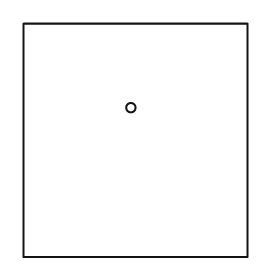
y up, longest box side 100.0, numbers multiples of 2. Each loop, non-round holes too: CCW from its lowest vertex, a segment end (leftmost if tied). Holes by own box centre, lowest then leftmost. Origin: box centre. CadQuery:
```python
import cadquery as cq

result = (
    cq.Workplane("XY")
    .moveTo(-48.0, -50.0)
    .lineTo(48.0, -50.0)
    .lineTo(48.0, 50.0)
    .lineTo(-48.0, 50.0)
    .close()
    .moveTo(-2.0, 14.0)
    .circle(2.0)
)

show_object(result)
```